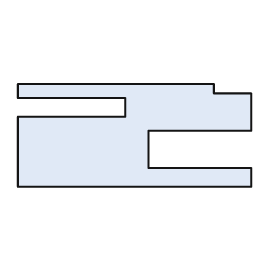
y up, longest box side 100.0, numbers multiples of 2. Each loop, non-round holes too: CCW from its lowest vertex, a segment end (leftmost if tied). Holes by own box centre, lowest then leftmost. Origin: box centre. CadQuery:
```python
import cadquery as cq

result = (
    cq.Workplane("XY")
    .moveTo(-50.0, -22.0)
    .lineTo(50.0, -22.0)
    .lineTo(50.0, -14.0)
    .lineTo(6.0, -14.0)
    .lineTo(6.0, 2.0)
    .lineTo(50.0, 2.0)
    .lineTo(50.0, 18.0)
    .lineTo(34.0, 18.0)
    .lineTo(34.0, 22.0)
    .lineTo(-50.0, 22.0)
    .lineTo(-50.0, 16.0)
    .lineTo(-4.0, 16.0)
    .lineTo(-4.0, 8.0)
    .lineTo(-50.0, 8.0)
    .close()
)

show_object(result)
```